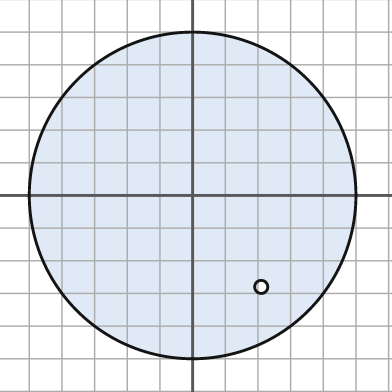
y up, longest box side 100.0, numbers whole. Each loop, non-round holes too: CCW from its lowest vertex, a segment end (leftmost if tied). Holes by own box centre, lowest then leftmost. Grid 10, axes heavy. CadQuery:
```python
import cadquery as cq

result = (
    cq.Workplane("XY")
    .moveTo(0.0, 0.0)
    .circle(50.0)
    .moveTo(21.0, -28.0)
    .circle(2.0)
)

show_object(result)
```